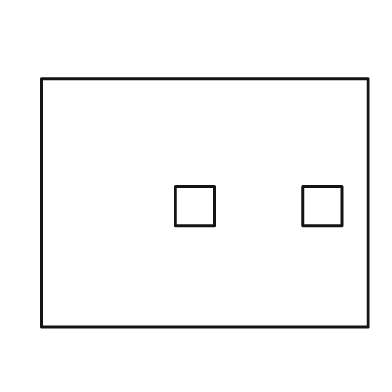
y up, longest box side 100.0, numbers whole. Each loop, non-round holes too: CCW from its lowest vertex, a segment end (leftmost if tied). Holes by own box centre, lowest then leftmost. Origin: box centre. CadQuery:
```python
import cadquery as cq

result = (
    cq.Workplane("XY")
    .moveTo(-50.0, -38.0)
    .lineTo(50.0, -38.0)
    .lineTo(50.0, 38.0)
    .lineTo(-50.0, 38.0)
    .close()
    .moveTo(-9.0, -7.0)
    .lineTo(3.0, -7.0)
    .lineTo(3.0, 5.0)
    .lineTo(-9.0, 5.0)
    .close()
    .moveTo(30.0, -7.0)
    .lineTo(42.0, -7.0)
    .lineTo(42.0, 5.0)
    .lineTo(30.0, 5.0)
    .close()
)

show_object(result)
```